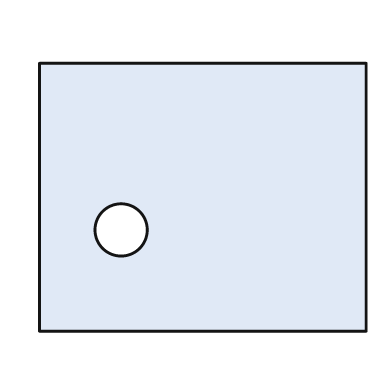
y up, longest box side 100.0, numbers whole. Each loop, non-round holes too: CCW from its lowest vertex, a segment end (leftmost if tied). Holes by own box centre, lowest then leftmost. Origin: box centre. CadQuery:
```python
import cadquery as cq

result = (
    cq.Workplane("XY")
    .moveTo(-50.0, -41.0)
    .lineTo(50.0, -41.0)
    .lineTo(50.0, 41.0)
    .lineTo(-50.0, 41.0)
    .close()
    .moveTo(-25.0, -10.0)
    .circle(8.0)
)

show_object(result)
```